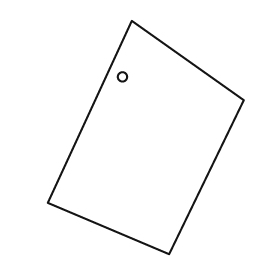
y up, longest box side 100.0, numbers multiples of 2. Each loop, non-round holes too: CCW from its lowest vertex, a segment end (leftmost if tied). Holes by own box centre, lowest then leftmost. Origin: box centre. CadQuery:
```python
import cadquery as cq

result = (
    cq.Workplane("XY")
    .moveTo(10.0, -50.0)
    .lineTo(42.0, 16.0)
    .lineTo(-6.0, 50.0)
    .lineTo(-42.0, -28.0)
    .close()
    .moveTo(-10.0, 26.0)
    .circle(2.0)
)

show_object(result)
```